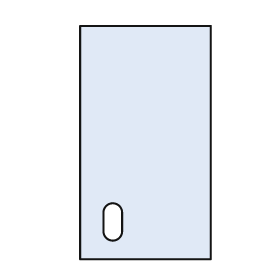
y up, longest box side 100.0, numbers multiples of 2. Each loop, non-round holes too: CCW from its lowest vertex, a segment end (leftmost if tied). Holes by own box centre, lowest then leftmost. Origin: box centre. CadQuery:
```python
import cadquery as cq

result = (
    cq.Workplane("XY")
    .moveTo(-28.0, -50.0)
    .lineTo(28.0, -50.0)
    .lineTo(28.0, 50.0)
    .lineTo(-28.0, 50.0)
    .close()
    .moveTo(-18.0, -38.0)
    .threePointArc((-14.0, -42.0), (-10.0, -38.0))
    .lineTo(-10.0, -30.0)
    .threePointArc((-14.0, -26.0), (-18.0, -30.0))
    .close()
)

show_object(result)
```